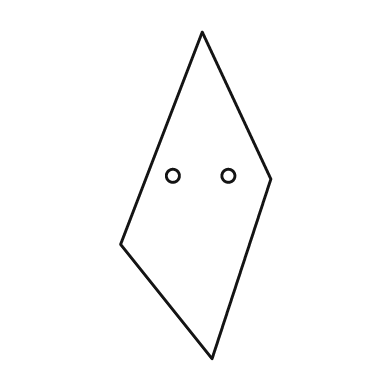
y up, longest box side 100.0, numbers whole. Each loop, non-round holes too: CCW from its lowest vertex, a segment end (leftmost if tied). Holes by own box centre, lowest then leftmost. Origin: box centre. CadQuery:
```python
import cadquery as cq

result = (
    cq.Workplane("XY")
    .moveTo(5.0, -50.0)
    .lineTo(23.0, 5.0)
    .lineTo(2.0, 50.0)
    .lineTo(-23.0, -15.0)
    .close()
    .moveTo(-7.0, 6.0)
    .circle(2.0)
    .moveTo(10.0, 6.0)
    .circle(2.0)
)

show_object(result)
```